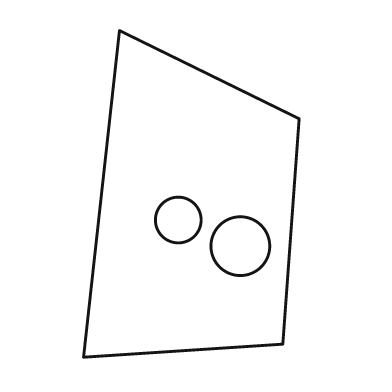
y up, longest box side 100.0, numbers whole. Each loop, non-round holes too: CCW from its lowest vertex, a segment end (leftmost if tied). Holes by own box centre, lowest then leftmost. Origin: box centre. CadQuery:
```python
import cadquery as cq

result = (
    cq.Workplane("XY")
    .moveTo(-33.0, -50.0)
    .lineTo(28.0, -46.0)
    .lineTo(33.0, 23.0)
    .lineTo(-22.0, 50.0)
    .close()
    .moveTo(15.0, -16.0)
    .circle(9.0)
    .moveTo(-4.0, -8.0)
    .circle(7.0)
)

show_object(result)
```